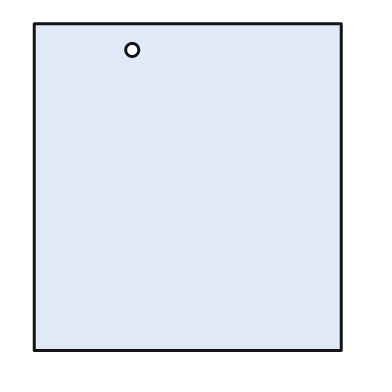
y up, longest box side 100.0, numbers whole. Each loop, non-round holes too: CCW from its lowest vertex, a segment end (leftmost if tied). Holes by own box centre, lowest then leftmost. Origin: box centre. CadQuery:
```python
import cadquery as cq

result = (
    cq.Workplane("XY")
    .moveTo(-47.0, -50.0)
    .lineTo(47.0, -50.0)
    .lineTo(47.0, 50.0)
    .lineTo(-47.0, 50.0)
    .close()
    .moveTo(-17.0, 42.0)
    .circle(2.0)
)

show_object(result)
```